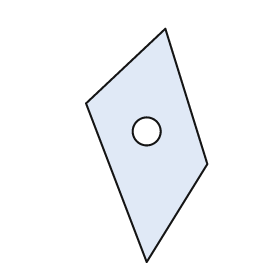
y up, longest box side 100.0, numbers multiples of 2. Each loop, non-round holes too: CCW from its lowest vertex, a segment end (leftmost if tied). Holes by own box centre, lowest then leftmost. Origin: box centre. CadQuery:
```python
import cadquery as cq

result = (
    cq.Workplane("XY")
    .moveTo(0.0, -50.0)
    .lineTo(26.0, -8.0)
    .lineTo(8.0, 50.0)
    .lineTo(-26.0, 18.0)
    .close()
    .moveTo(0.0, 6.0)
    .circle(6.0)
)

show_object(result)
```